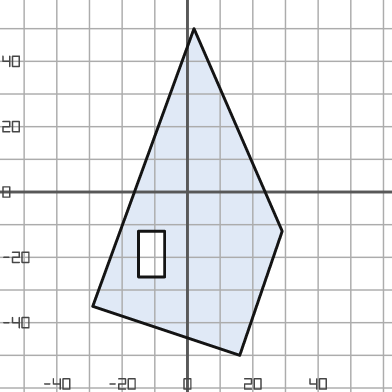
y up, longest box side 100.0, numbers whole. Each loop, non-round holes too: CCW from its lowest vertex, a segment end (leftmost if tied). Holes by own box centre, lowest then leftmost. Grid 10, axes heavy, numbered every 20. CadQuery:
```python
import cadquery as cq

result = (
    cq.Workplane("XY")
    .moveTo(16.0, -50.0)
    .lineTo(29.0, -12.0)
    .lineTo(2.0, 50.0)
    .lineTo(-29.0, -35.0)
    .close()
    .moveTo(-15.0, -26.0)
    .lineTo(-7.0, -26.0)
    .lineTo(-7.0, -12.0)
    .lineTo(-15.0, -12.0)
    .close()
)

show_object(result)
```